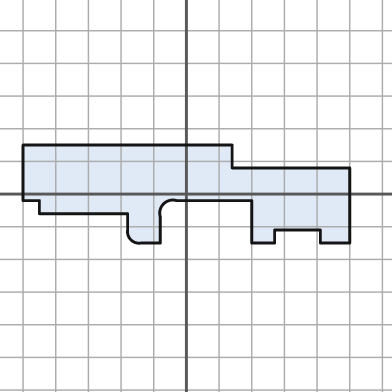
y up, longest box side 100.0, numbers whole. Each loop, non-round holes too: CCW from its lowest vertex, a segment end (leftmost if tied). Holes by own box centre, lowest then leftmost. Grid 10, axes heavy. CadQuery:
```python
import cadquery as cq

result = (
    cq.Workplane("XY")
    .moveTo(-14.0, -15.0)
    .lineTo(-8.0, -15.0)
    .lineTo(-8.0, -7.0)
    .threePointArc((-7.0, -3.0), (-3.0, -2.0))
    .lineTo(20.0, -2.0)
    .lineTo(20.0, -15.0)
    .lineTo(27.0, -15.0)
    .lineTo(27.0, -11.0)
    .lineTo(41.0, -11.0)
    .lineTo(41.0, -15.0)
    .lineTo(50.0, -15.0)
    .lineTo(50.0, 8.0)
    .lineTo(14.0, 8.0)
    .lineTo(14.0, 15.0)
    .lineTo(-50.0, 15.0)
    .lineTo(-50.0, -2.0)
    .lineTo(-45.0, -2.0)
    .lineTo(-45.0, -6.0)
    .lineTo(-18.0, -6.0)
    .lineTo(-18.0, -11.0)
    .threePointArc((-17.0, -14.0), (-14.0, -15.0))
    .close()
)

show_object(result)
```